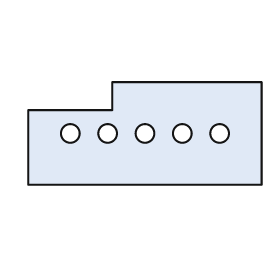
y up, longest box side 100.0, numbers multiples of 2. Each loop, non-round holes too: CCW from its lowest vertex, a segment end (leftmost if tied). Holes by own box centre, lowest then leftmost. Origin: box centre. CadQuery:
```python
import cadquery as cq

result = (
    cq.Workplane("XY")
    .moveTo(-50.0, -22.0)
    .lineTo(50.0, -22.0)
    .lineTo(50.0, 22.0)
    .lineTo(-14.0, 22.0)
    .lineTo(-14.0, 10.0)
    .lineTo(-50.0, 10.0)
    .close()
    .moveTo(-32.0, 0.0)
    .circle(4.0)
    .moveTo(-16.0, 0.0)
    .circle(4.0)
    .moveTo(0.0, 0.0)
    .circle(4.0)
    .moveTo(16.0, 0.0)
    .circle(4.0)
    .moveTo(32.0, 0.0)
    .circle(4.0)
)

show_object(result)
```